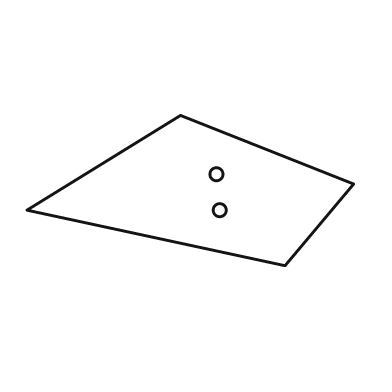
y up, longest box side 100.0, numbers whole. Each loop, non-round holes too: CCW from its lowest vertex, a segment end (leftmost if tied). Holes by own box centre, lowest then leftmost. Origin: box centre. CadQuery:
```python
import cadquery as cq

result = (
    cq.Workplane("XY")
    .moveTo(29.0, -23.0)
    .lineTo(50.0, 2.0)
    .lineTo(-3.0, 23.0)
    .lineTo(-50.0, -6.0)
    .close()
    .moveTo(9.0, -6.0)
    .circle(2.0)
    .moveTo(8.0, 5.0)
    .circle(2.0)
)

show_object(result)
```